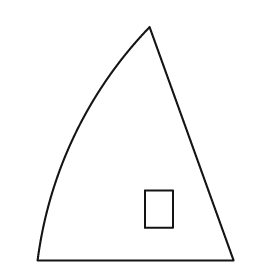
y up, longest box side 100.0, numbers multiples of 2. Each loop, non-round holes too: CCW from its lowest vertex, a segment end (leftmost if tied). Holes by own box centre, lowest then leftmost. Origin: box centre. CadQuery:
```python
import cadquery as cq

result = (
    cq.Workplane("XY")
    .moveTo(-42.0, -50.0)
    .lineTo(42.0, -50.0)
    .lineTo(6.0, 50.0)
    .threePointArc((-26.0, 4.0), (-42.0, -50.0))
    .close()
    .moveTo(4.0, -36.0)
    .lineTo(16.0, -36.0)
    .lineTo(16.0, -20.0)
    .lineTo(4.0, -20.0)
    .close()
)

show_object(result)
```